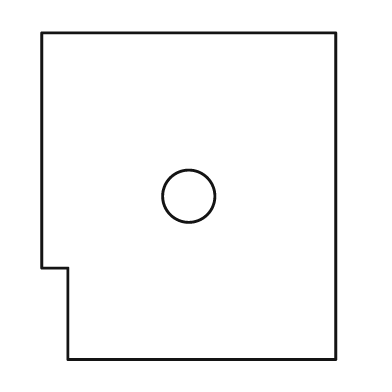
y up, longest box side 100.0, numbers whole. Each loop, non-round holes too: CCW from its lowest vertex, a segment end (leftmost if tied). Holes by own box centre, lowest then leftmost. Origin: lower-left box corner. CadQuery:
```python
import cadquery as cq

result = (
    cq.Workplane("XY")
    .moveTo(8.0, 0.0)
    .lineTo(90.0, 0.0)
    .lineTo(90.0, 100.0)
    .lineTo(0.0, 100.0)
    .lineTo(0.0, 28.0)
    .lineTo(8.0, 28.0)
    .close()
    .moveTo(45.0, 50.0)
    .circle(8.0)
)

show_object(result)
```